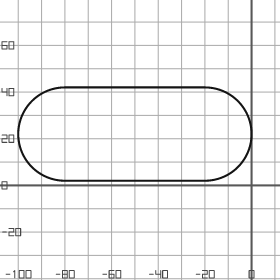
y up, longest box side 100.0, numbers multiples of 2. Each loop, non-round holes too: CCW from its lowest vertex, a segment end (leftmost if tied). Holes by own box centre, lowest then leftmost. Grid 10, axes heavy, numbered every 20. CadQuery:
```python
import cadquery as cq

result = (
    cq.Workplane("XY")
    .moveTo(-80.0, 2.0)
    .lineTo(-20.0, 2.0)
    .threePointArc((0.0, 22.0), (-20.0, 42.0))
    .lineTo(-80.0, 42.0)
    .threePointArc((-100.0, 22.0), (-80.0, 2.0))
    .close()
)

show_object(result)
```